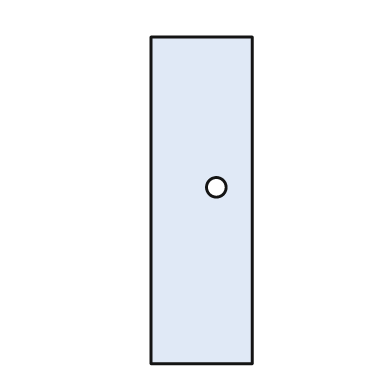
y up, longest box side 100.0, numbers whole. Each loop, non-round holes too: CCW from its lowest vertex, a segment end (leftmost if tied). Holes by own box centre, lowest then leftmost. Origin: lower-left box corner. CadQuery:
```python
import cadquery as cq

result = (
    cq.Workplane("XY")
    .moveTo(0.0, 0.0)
    .lineTo(31.0, 0.0)
    .lineTo(31.0, 100.0)
    .lineTo(0.0, 100.0)
    .close()
    .moveTo(20.0, 54.0)
    .circle(3.0)
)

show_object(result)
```